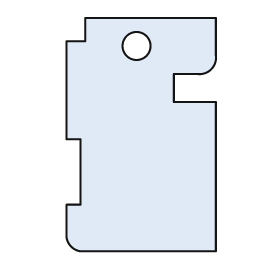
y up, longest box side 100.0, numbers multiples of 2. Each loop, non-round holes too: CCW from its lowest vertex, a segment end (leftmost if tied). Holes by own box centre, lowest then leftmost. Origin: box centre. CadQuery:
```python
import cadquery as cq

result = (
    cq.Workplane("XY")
    .moveTo(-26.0, -50.0)
    .lineTo(32.0, -50.0)
    .lineTo(32.0, 14.0)
    .lineTo(14.0, 14.0)
    .lineTo(14.0, 26.0)
    .lineTo(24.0, 26.0)
    .threePointArc((30.0, 28.0), (32.0, 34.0))
    .lineTo(32.0, 50.0)
    .lineTo(-24.0, 50.0)
    .lineTo(-24.0, 40.0)
    .lineTo(-32.0, 40.0)
    .lineTo(-32.0, -2.0)
    .lineTo(-26.0, -2.0)
    .lineTo(-26.0, -30.0)
    .lineTo(-32.0, -30.0)
    .lineTo(-32.0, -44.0)
    .threePointArc((-30.0, -48.0), (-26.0, -50.0))
    .close()
    .moveTo(-2.0, 38.0)
    .circle(6.0)
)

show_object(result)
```